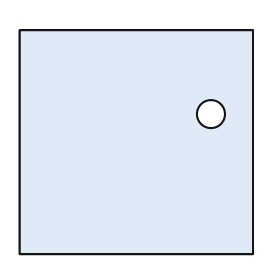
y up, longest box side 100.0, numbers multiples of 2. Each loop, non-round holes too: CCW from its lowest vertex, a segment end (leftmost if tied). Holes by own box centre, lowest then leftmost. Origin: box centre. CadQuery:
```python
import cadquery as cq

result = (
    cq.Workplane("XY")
    .moveTo(-50.0, -48.0)
    .lineTo(50.0, -48.0)
    .lineTo(50.0, 48.0)
    .lineTo(-50.0, 48.0)
    .close()
    .moveTo(32.0, 12.0)
    .circle(6.0)
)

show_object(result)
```